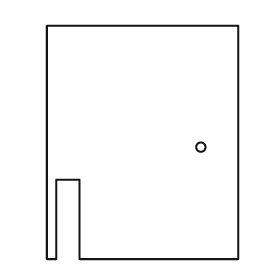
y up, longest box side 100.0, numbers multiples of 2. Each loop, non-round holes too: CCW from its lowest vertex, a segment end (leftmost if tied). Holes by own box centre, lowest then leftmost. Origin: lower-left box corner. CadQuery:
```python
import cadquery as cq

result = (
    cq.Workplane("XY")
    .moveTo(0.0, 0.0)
    .lineTo(4.0, 0.0)
    .lineTo(4.0, 34.0)
    .lineTo(14.0, 34.0)
    .lineTo(14.0, 0.0)
    .lineTo(82.0, 0.0)
    .lineTo(82.0, 100.0)
    .lineTo(0.0, 100.0)
    .close()
    .moveTo(66.0, 48.0)
    .circle(2.0)
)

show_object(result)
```